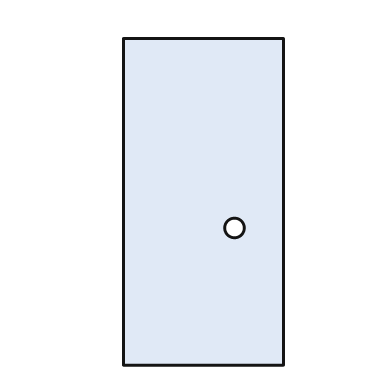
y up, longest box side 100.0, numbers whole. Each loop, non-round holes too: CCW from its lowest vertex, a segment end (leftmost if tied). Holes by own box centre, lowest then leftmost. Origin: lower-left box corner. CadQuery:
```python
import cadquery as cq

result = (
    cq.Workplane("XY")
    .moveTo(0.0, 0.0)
    .lineTo(49.0, 0.0)
    .lineTo(49.0, 100.0)
    .lineTo(0.0, 100.0)
    .close()
    .moveTo(34.0, 42.0)
    .circle(3.0)
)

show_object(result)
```